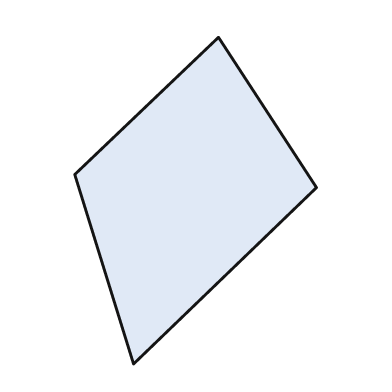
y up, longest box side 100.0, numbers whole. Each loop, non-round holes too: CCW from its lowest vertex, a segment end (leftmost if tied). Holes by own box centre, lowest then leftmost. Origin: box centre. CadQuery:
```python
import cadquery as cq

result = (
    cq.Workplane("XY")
    .moveTo(-19.0, -50.0)
    .lineTo(37.0, 4.0)
    .lineTo(7.0, 50.0)
    .lineTo(-37.0, 8.0)
    .close()
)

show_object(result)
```